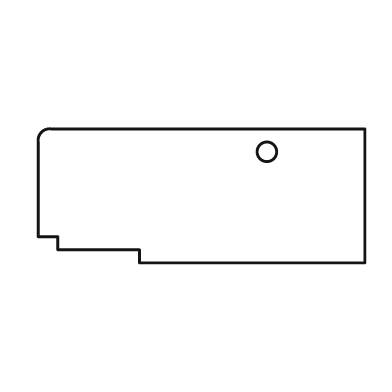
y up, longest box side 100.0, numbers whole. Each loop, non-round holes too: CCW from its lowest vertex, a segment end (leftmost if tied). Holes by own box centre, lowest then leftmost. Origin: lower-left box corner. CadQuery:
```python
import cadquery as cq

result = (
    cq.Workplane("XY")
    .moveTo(31.0, 0.0)
    .lineTo(100.0, 0.0)
    .lineTo(100.0, 41.0)
    .lineTo(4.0, 41.0)
    .threePointArc((1.0, 40.0), (0.0, 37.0))
    .lineTo(0.0, 8.0)
    .lineTo(6.0, 8.0)
    .lineTo(6.0, 4.0)
    .lineTo(31.0, 4.0)
    .close()
    .moveTo(70.0, 34.0)
    .circle(3.0)
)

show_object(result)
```